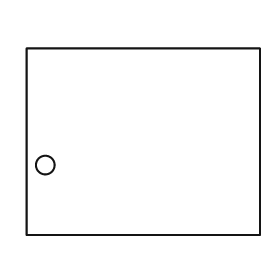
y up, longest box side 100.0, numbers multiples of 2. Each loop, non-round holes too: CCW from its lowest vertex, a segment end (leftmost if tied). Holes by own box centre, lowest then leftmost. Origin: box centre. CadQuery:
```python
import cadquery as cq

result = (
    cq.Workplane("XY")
    .moveTo(-50.0, -40.0)
    .lineTo(50.0, -40.0)
    .lineTo(50.0, 40.0)
    .lineTo(-50.0, 40.0)
    .close()
    .moveTo(-42.0, -10.0)
    .circle(4.0)
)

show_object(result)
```